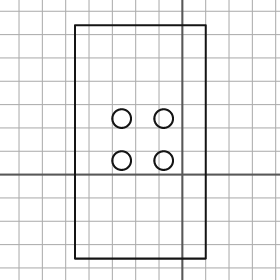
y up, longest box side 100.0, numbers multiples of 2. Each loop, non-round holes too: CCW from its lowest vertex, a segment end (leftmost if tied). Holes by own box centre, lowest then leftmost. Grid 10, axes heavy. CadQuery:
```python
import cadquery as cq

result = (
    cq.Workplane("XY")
    .moveTo(-46.0, -36.0)
    .lineTo(10.0, -36.0)
    .lineTo(10.0, 64.0)
    .lineTo(-46.0, 64.0)
    .close()
    .moveTo(-26.0, 6.0)
    .circle(4.0)
    .moveTo(-8.0, 6.0)
    .circle(4.0)
    .moveTo(-26.0, 24.0)
    .circle(4.0)
    .moveTo(-8.0, 24.0)
    .circle(4.0)
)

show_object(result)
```